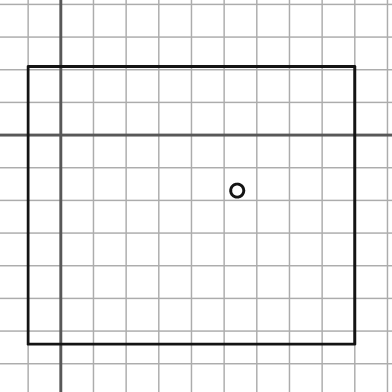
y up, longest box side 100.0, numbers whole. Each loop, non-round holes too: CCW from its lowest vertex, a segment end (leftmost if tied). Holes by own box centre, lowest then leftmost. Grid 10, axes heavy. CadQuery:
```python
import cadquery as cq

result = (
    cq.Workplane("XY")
    .moveTo(-10.0, -64.0)
    .lineTo(90.0, -64.0)
    .lineTo(90.0, 21.0)
    .lineTo(-10.0, 21.0)
    .close()
    .moveTo(54.0, -17.0)
    .circle(2.0)
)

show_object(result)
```